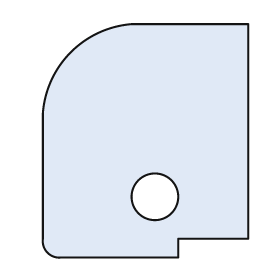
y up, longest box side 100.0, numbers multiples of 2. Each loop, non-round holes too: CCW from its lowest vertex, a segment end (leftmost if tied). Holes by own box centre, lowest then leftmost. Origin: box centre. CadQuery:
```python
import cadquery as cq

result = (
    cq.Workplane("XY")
    .moveTo(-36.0, -50.0)
    .lineTo(14.0, -50.0)
    .lineTo(14.0, -42.0)
    .lineTo(44.0, -42.0)
    .lineTo(44.0, 50.0)
    .lineTo(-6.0, 50.0)
    .threePointArc((-32.0, 38.0), (-44.0, 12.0))
    .lineTo(-44.0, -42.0)
    .threePointArc((-42.0, -48.0), (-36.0, -50.0))
    .close()
    .moveTo(4.0, -24.0)
    .circle(10.0)
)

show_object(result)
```